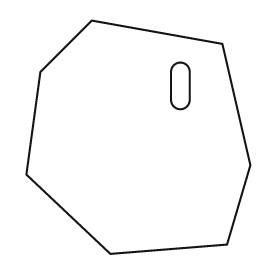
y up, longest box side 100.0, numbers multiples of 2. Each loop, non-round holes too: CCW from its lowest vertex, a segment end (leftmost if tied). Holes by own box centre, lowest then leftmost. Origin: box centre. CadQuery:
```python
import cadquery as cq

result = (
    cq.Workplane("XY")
    .moveTo(-12.0, -50.0)
    .lineTo(38.0, -46.0)
    .lineTo(48.0, -12.0)
    .lineTo(36.0, 40.0)
    .lineTo(-20.0, 50.0)
    .lineTo(-42.0, 28.0)
    .lineTo(-48.0, -16.0)
    .close()
    .moveTo(14.0, 16.0)
    .threePointArc((18.0, 12.0), (22.0, 16.0))
    .lineTo(22.0, 28.0)
    .threePointArc((18.0, 32.0), (14.0, 28.0))
    .close()
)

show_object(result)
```